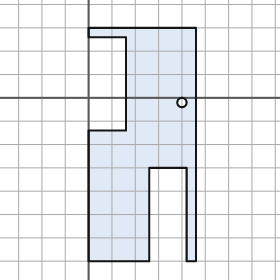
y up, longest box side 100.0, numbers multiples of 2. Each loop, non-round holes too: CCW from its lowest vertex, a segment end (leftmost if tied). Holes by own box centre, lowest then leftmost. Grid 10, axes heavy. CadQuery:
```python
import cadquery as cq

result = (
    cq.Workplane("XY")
    .moveTo(0.0, -70.0)
    .lineTo(26.0, -70.0)
    .lineTo(26.0, -30.0)
    .lineTo(42.0, -30.0)
    .lineTo(42.0, -70.0)
    .lineTo(46.0, -70.0)
    .lineTo(46.0, 30.0)
    .lineTo(0.0, 30.0)
    .lineTo(0.0, 26.0)
    .lineTo(16.0, 26.0)
    .lineTo(16.0, -14.0)
    .lineTo(0.0, -14.0)
    .close()
    .moveTo(40.0, -2.0)
    .circle(2.0)
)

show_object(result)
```